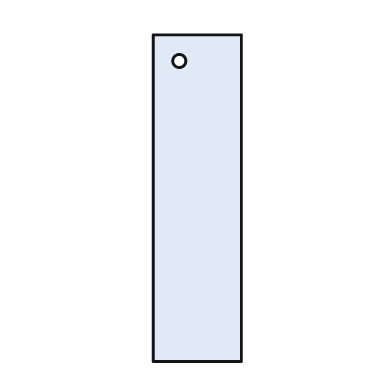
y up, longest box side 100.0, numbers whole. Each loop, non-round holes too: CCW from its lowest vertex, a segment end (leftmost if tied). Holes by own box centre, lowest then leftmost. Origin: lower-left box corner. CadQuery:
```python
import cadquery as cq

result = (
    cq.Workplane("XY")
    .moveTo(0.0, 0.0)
    .lineTo(27.0, 0.0)
    .lineTo(27.0, 100.0)
    .lineTo(0.0, 100.0)
    .close()
    .moveTo(8.0, 92.0)
    .circle(2.0)
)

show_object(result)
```